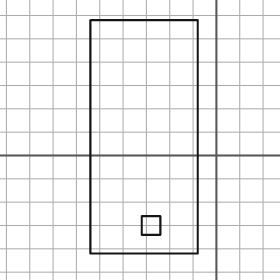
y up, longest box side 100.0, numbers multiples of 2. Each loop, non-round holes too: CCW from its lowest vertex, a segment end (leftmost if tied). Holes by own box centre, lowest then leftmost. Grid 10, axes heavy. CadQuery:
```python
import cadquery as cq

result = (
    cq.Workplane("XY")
    .moveTo(-54.0, -42.0)
    .lineTo(-8.0, -42.0)
    .lineTo(-8.0, 58.0)
    .lineTo(-54.0, 58.0)
    .close()
    .moveTo(-32.0, -34.0)
    .lineTo(-24.0, -34.0)
    .lineTo(-24.0, -26.0)
    .lineTo(-32.0, -26.0)
    .close()
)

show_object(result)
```